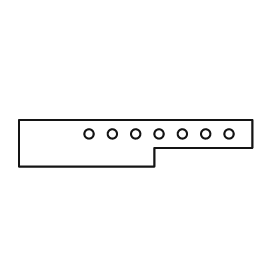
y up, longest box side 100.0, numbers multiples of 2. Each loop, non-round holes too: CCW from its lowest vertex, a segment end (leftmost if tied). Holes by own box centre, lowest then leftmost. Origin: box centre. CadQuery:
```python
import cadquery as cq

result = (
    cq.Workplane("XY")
    .moveTo(-50.0, -10.0)
    .lineTo(8.0, -10.0)
    .lineTo(8.0, -2.0)
    .lineTo(50.0, -2.0)
    .lineTo(50.0, 10.0)
    .lineTo(-50.0, 10.0)
    .close()
    .moveTo(-20.0, 4.0)
    .circle(2.0)
    .moveTo(-10.0, 4.0)
    .circle(2.0)
    .moveTo(0.0, 4.0)
    .circle(2.0)
    .moveTo(10.0, 4.0)
    .circle(2.0)
    .moveTo(20.0, 4.0)
    .circle(2.0)
    .moveTo(30.0, 4.0)
    .circle(2.0)
    .moveTo(40.0, 4.0)
    .circle(2.0)
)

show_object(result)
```